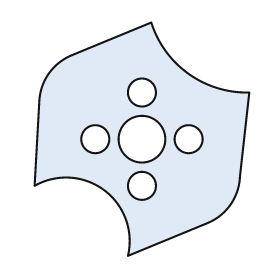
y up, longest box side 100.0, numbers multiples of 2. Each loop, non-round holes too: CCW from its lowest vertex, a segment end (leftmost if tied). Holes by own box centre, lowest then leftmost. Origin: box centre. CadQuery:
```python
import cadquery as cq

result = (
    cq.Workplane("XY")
    .moveTo(-6.0, -50.0)
    .lineTo(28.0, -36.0)
    .threePointArc((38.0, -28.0), (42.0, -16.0))
    .lineTo(46.0, 20.0)
    .threePointArc((20.0, 28.0), (4.0, 50.0))
    .lineTo(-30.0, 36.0)
    .threePointArc((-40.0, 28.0), (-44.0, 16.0))
    .lineTo(-46.0, -20.0)
    .threePointArc((-16.0, -22.0), (-6.0, -50.0))
    .close()
    .moveTo(0.0, -20.0)
    .circle(6.0)
    .moveTo(-20.0, 0.0)
    .circle(6.0)
    .moveTo(0.0, 0.0)
    .circle(10.0)
    .moveTo(20.0, 0.0)
    .circle(6.0)
    .moveTo(0.0, 20.0)
    .circle(6.0)
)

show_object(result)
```